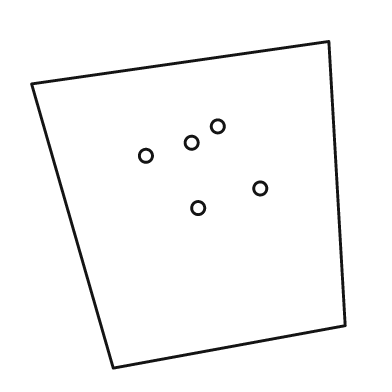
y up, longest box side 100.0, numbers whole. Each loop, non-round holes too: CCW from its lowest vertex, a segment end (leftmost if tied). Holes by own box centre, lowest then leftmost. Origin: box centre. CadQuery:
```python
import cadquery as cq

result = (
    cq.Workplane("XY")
    .moveTo(-23.0, -50.0)
    .lineTo(48.0, -37.0)
    .lineTo(43.0, 50.0)
    .lineTo(-48.0, 37.0)
    .close()
    .moveTo(3.0, -1.0)
    .circle(2.0)
    .moveTo(22.0, 5.0)
    .circle(2.0)
    .moveTo(-13.0, 15.0)
    .circle(2.0)
    .moveTo(1.0, 19.0)
    .circle(2.0)
    .moveTo(9.0, 24.0)
    .circle(2.0)
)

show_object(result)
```